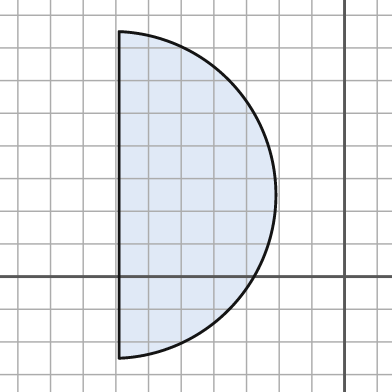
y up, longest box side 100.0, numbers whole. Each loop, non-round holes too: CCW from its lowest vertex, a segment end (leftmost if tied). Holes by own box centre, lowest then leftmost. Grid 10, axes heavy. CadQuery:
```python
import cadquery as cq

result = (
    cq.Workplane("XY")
    .moveTo(-69.0, -25.0)
    .threePointArc((-21.0, 25.0), (-69.0, 75.0))
    .close()
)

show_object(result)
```